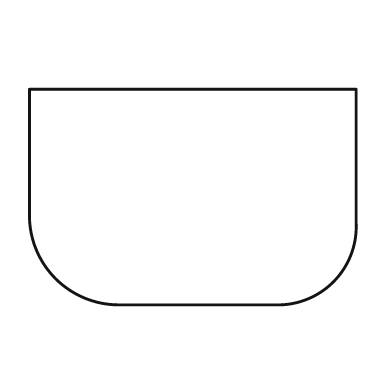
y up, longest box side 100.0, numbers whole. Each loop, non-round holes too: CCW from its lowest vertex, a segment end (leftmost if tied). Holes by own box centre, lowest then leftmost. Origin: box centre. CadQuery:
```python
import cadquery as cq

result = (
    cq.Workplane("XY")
    .moveTo(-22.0, -33.0)
    .lineTo(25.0, -33.0)
    .threePointArc((43.0, -26.0), (50.0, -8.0))
    .lineTo(50.0, 33.0)
    .lineTo(-50.0, 33.0)
    .lineTo(-50.0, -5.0)
    .threePointArc((-42.0, -25.0), (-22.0, -33.0))
    .close()
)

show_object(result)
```